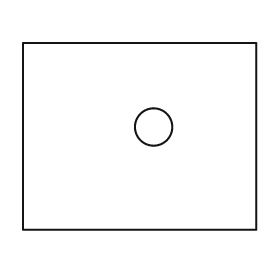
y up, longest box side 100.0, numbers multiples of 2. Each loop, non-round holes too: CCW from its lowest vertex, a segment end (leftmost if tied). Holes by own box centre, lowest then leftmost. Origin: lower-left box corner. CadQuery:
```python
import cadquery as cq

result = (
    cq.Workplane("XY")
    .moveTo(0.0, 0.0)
    .lineTo(100.0, 0.0)
    .lineTo(100.0, 80.0)
    .lineTo(0.0, 80.0)
    .close()
    .moveTo(56.0, 44.0)
    .circle(8.0)
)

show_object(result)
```